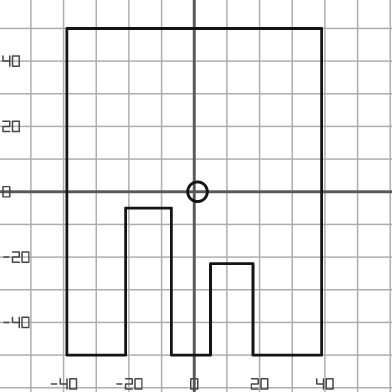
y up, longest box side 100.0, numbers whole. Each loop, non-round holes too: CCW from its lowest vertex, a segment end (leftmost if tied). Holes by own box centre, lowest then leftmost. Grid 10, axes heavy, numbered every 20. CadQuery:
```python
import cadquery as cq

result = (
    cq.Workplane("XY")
    .moveTo(-39.0, -50.0)
    .lineTo(-21.0, -50.0)
    .lineTo(-21.0, -5.0)
    .lineTo(-7.0, -5.0)
    .lineTo(-7.0, -50.0)
    .lineTo(5.0, -50.0)
    .lineTo(5.0, -22.0)
    .lineTo(18.0, -22.0)
    .lineTo(18.0, -50.0)
    .lineTo(39.0, -50.0)
    .lineTo(39.0, 50.0)
    .lineTo(-39.0, 50.0)
    .close()
    .moveTo(1.0, 0.0)
    .circle(3.0)
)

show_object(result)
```